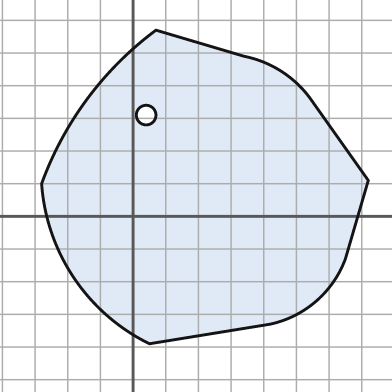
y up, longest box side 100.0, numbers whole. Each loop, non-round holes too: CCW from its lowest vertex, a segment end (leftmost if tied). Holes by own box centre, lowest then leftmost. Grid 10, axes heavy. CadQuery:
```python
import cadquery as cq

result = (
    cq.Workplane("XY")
    .moveTo(5.0, -39.0)
    .lineTo(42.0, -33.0)
    .threePointArc((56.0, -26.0), (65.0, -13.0))
    .lineTo(72.0, 11.0)
    .lineTo(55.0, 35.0)
    .threePointArc((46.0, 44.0), (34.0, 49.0))
    .lineTo(7.0, 57.0)
    .threePointArc((-14.0, 36.0), (-28.0, 10.0))
    .threePointArc((-18.0, -19.0), (5.0, -39.0))
    .close()
    .moveTo(4.0, 31.0)
    .circle(3.0)
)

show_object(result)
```